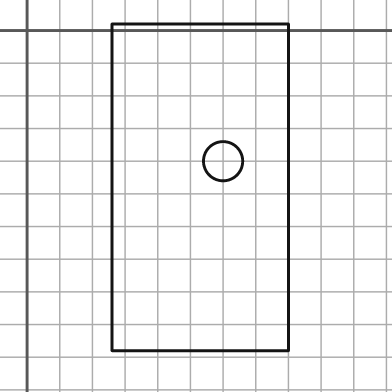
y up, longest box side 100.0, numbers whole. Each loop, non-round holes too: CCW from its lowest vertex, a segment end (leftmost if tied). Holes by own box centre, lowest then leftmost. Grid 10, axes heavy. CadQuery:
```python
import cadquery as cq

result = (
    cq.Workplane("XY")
    .moveTo(26.0, -98.0)
    .lineTo(80.0, -98.0)
    .lineTo(80.0, 2.0)
    .lineTo(26.0, 2.0)
    .close()
    .moveTo(60.0, -40.0)
    .circle(6.0)
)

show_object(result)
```